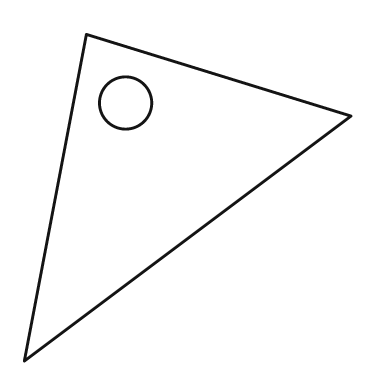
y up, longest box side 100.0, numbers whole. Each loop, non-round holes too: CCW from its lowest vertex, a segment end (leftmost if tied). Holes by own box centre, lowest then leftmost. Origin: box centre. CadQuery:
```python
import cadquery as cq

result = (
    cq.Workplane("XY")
    .moveTo(-50.0, -50.0)
    .lineTo(50.0, 25.0)
    .lineTo(-31.0, 50.0)
    .close()
    .moveTo(-19.0, 29.0)
    .circle(8.0)
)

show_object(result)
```